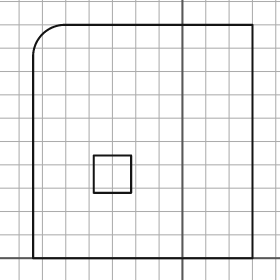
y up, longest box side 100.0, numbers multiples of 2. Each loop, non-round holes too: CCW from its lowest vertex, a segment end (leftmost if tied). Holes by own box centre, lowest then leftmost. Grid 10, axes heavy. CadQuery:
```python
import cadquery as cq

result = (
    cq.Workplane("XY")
    .moveTo(-64.0, 0.0)
    .lineTo(30.0, 0.0)
    .lineTo(30.0, 100.0)
    .lineTo(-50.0, 100.0)
    .threePointArc((-60.0, 96.0), (-64.0, 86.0))
    .close()
    .moveTo(-38.0, 28.0)
    .lineTo(-22.0, 28.0)
    .lineTo(-22.0, 44.0)
    .lineTo(-38.0, 44.0)
    .close()
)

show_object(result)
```